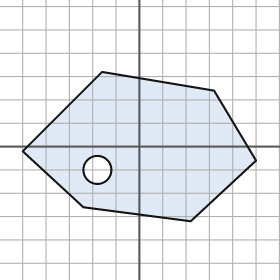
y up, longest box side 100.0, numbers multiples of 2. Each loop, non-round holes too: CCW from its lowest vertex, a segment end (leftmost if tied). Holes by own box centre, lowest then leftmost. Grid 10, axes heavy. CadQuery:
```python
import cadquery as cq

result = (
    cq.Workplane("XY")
    .moveTo(22.0, -32.0)
    .lineTo(50.0, -6.0)
    .lineTo(32.0, 24.0)
    .lineTo(-16.0, 32.0)
    .lineTo(-50.0, -2.0)
    .lineTo(-24.0, -26.0)
    .close()
    .moveTo(-18.0, -10.0)
    .circle(6.0)
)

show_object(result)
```